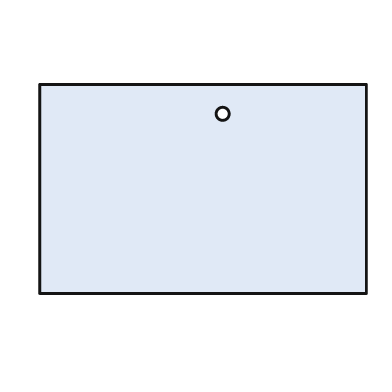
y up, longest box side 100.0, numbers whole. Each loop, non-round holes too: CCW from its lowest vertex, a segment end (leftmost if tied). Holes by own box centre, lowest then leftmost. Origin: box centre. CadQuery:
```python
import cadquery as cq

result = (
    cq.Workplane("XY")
    .moveTo(-50.0, -32.0)
    .lineTo(50.0, -32.0)
    .lineTo(50.0, 32.0)
    .lineTo(-50.0, 32.0)
    .close()
    .moveTo(6.0, 23.0)
    .circle(2.0)
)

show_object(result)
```